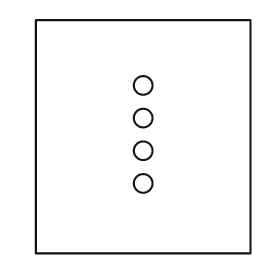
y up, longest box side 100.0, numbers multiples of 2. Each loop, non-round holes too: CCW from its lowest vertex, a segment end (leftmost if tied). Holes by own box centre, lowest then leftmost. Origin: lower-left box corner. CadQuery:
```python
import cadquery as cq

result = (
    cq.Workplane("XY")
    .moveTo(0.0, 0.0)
    .lineTo(92.0, 0.0)
    .lineTo(92.0, 100.0)
    .lineTo(0.0, 100.0)
    .close()
    .moveTo(46.0, 30.0)
    .circle(4.0)
    .moveTo(46.0, 44.0)
    .circle(4.0)
    .moveTo(46.0, 58.0)
    .circle(4.0)
    .moveTo(46.0, 72.0)
    .circle(4.0)
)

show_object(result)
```